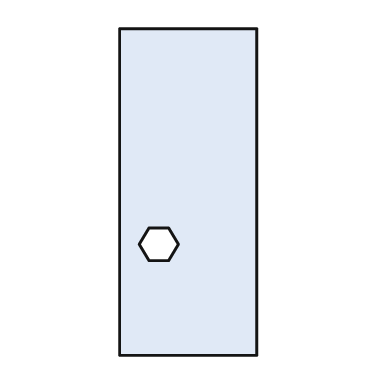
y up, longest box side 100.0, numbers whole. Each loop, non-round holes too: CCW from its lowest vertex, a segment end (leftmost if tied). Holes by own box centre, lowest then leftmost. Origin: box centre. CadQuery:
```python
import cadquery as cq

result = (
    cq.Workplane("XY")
    .moveTo(-21.0, -50.0)
    .lineTo(21.0, -50.0)
    .lineTo(21.0, 50.0)
    .lineTo(-21.0, 50.0)
    .close()
    .moveTo(-12.0, -21.0)
    .lineTo(-6.0, -21.0)
    .lineTo(-3.0, -16.0)
    .lineTo(-6.0, -11.0)
    .lineTo(-12.0, -11.0)
    .lineTo(-15.0, -16.0)
    .close()
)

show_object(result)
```